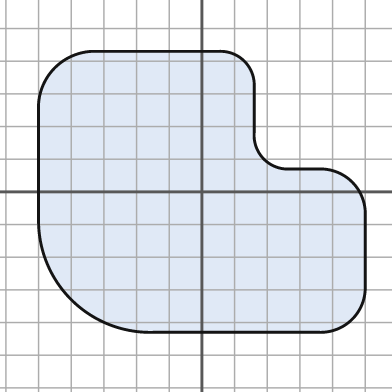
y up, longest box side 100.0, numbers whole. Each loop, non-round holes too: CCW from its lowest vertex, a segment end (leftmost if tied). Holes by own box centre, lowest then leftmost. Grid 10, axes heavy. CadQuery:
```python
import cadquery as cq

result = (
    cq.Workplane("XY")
    .moveTo(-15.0, -43.0)
    .lineTo(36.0, -43.0)
    .threePointArc((46.0, -39.0), (50.0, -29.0))
    .lineTo(50.0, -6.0)
    .threePointArc((46.0, 3.0), (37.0, 7.0))
    .lineTo(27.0, 7.0)
    .threePointArc((19.0, 10.0), (16.0, 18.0))
    .lineTo(16.0, 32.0)
    .threePointArc((13.0, 40.0), (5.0, 43.0))
    .lineTo(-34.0, 43.0)
    .threePointArc((-45.0, 38.0), (-50.0, 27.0))
    .lineTo(-50.0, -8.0)
    .threePointArc((-40.0, -33.0), (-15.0, -43.0))
    .close()
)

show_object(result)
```